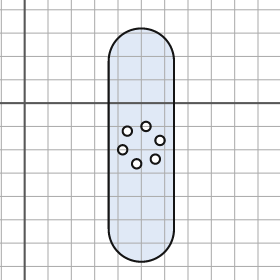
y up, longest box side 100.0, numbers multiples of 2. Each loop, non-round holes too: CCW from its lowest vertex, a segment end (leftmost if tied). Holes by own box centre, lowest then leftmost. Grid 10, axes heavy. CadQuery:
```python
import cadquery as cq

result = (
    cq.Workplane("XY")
    .moveTo(36.0, -54.0)
    .threePointArc((50.0, -68.0), (64.0, -54.0))
    .lineTo(64.0, 18.0)
    .threePointArc((50.0, 32.0), (36.0, 18.0))
    .close()
    .moveTo(48.0, -26.0)
    .circle(2.0)
    .moveTo(56.0, -24.0)
    .circle(2.0)
    .moveTo(42.0, -20.0)
    .circle(2.0)
    .moveTo(58.0, -16.0)
    .circle(2.0)
    .moveTo(44.0, -12.0)
    .circle(2.0)
    .moveTo(52.0, -10.0)
    .circle(2.0)
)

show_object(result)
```